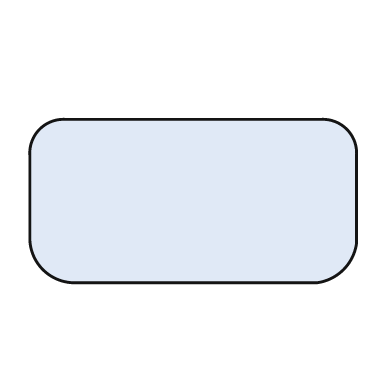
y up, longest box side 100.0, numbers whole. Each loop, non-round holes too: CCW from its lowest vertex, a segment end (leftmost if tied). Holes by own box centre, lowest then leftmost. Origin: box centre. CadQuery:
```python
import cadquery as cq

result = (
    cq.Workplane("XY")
    .moveTo(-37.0, -25.0)
    .lineTo(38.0, -25.0)
    .threePointArc((46.0, -21.0), (50.0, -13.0))
    .lineTo(50.0, 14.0)
    .threePointArc((47.0, 22.0), (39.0, 25.0))
    .lineTo(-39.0, 25.0)
    .threePointArc((-47.0, 22.0), (-50.0, 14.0))
    .lineTo(-50.0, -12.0)
    .threePointArc((-46.0, -21.0), (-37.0, -25.0))
    .close()
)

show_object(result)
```